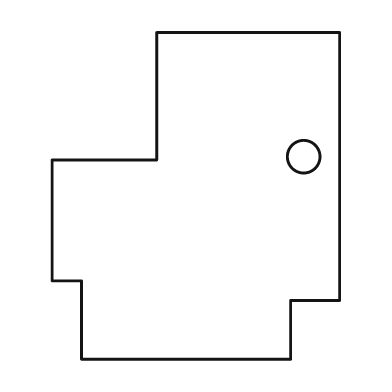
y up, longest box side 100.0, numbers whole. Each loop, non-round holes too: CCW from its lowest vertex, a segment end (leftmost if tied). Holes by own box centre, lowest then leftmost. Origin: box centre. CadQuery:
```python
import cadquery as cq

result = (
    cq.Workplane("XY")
    .moveTo(-35.0, -50.0)
    .lineTo(29.0, -50.0)
    .lineTo(29.0, -32.0)
    .lineTo(44.0, -32.0)
    .lineTo(44.0, 50.0)
    .lineTo(-12.0, 50.0)
    .lineTo(-12.0, 11.0)
    .lineTo(-44.0, 11.0)
    .lineTo(-44.0, -26.0)
    .lineTo(-35.0, -26.0)
    .close()
    .moveTo(33.0, 12.0)
    .circle(5.0)
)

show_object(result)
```